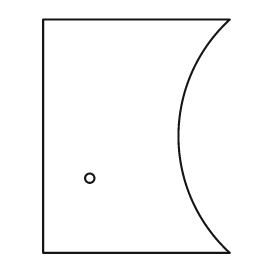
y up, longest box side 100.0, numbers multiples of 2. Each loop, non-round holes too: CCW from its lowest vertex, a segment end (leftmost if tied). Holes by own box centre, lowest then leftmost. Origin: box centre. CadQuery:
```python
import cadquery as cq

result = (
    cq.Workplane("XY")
    .moveTo(-40.0, -50.0)
    .lineTo(40.0, -50.0)
    .threePointArc((18.0, 0.0), (40.0, 50.0))
    .lineTo(-40.0, 50.0)
    .close()
    .moveTo(-20.0, -18.0)
    .circle(2.0)
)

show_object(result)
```